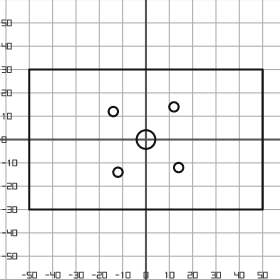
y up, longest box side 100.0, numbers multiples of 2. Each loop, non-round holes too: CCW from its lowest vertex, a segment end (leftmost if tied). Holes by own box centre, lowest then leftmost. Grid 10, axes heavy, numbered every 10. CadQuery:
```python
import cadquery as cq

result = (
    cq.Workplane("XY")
    .moveTo(-50.0, -30.0)
    .lineTo(50.0, -30.0)
    .lineTo(50.0, 30.0)
    .lineTo(-50.0, 30.0)
    .close()
    .moveTo(-12.0, -14.0)
    .circle(2.0)
    .moveTo(14.0, -12.0)
    .circle(2.0)
    .moveTo(0.0, 0.0)
    .circle(4.0)
    .moveTo(-14.0, 12.0)
    .circle(2.0)
    .moveTo(12.0, 14.0)
    .circle(2.0)
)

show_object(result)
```